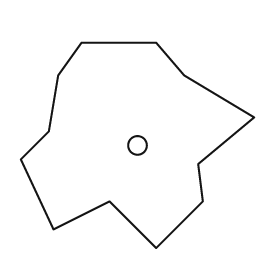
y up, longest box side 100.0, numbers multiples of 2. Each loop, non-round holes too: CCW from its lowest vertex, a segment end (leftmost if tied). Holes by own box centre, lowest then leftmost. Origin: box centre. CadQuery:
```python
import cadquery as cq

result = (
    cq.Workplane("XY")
    .moveTo(8.0, -44.0)
    .lineTo(28.0, -24.0)
    .lineTo(26.0, -8.0)
    .lineTo(50.0, 12.0)
    .lineTo(20.0, 30.0)
    .lineTo(8.0, 44.0)
    .lineTo(-24.0, 44.0)
    .lineTo(-34.0, 30.0)
    .lineTo(-38.0, 6.0)
    .lineTo(-50.0, -6.0)
    .lineTo(-36.0, -36.0)
    .lineTo(-12.0, -24.0)
    .close()
    .moveTo(0.0, 0.0)
    .circle(4.0)
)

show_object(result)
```